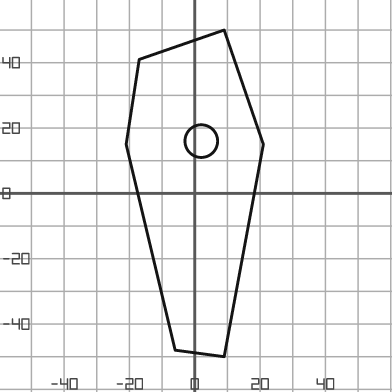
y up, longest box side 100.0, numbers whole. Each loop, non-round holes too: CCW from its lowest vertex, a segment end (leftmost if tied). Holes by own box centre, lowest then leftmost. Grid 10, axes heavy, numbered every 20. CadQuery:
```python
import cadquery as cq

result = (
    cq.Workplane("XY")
    .moveTo(9.0, -50.0)
    .lineTo(21.0, 15.0)
    .lineTo(9.0, 50.0)
    .lineTo(-17.0, 41.0)
    .lineTo(-21.0, 15.0)
    .lineTo(-6.0, -48.0)
    .close()
    .moveTo(2.0, 16.0)
    .circle(5.0)
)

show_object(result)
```